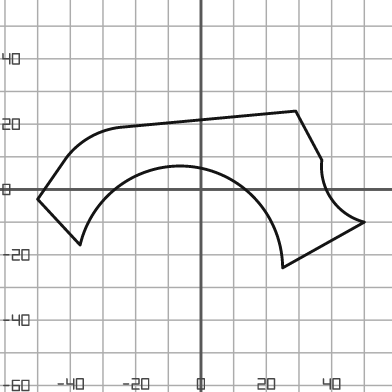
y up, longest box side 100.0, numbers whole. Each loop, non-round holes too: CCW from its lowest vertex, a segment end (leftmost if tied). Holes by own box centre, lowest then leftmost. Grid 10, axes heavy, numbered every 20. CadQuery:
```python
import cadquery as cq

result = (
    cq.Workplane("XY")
    .moveTo(25.0, -24.0)
    .lineTo(50.0, -10.0)
    .threePointArc((40.0, -3.0), (37.0, 9.0))
    .lineTo(29.0, 24.0)
    .lineTo(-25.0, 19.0)
    .threePointArc((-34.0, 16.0), (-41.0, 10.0))
    .lineTo(-50.0, -3.0)
    .lineTo(-37.0, -17.0)
    .threePointArc((-3.0, 7.0), (25.0, -24.0))
    .close()
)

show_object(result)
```